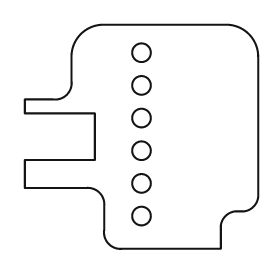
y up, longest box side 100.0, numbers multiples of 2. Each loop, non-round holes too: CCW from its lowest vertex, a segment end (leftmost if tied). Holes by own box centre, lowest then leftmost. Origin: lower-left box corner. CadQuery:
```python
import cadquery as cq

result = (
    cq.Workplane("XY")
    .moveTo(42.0, 0.0)
    .lineTo(84.0, 0.0)
    .lineTo(84.0, 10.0)
    .threePointArc((86.0, 14.0), (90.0, 16.0))
    .lineTo(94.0, 16.0)
    .threePointArc((98.0, 18.0), (100.0, 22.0))
    .lineTo(100.0, 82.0)
    .threePointArc((96.0, 92.0), (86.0, 96.0))
    .lineTo(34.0, 96.0)
    .threePointArc((24.0, 92.0), (20.0, 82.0))
    .lineTo(20.0, 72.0)
    .threePointArc((18.0, 66.0), (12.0, 64.0))
    .lineTo(0.0, 64.0)
    .lineTo(0.0, 58.0)
    .lineTo(30.0, 58.0)
    .lineTo(30.0, 38.0)
    .lineTo(0.0, 38.0)
    .lineTo(0.0, 26.0)
    .lineTo(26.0, 26.0)
    .threePointArc((32.0, 24.0), (34.0, 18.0))
    .lineTo(34.0, 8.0)
    .threePointArc((36.0, 2.0), (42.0, 0.0))
    .close()
    .moveTo(50.0, 14.0)
    .circle(4.0)
    .moveTo(50.0, 28.0)
    .circle(4.0)
    .moveTo(50.0, 42.0)
    .circle(4.0)
    .moveTo(50.0, 56.0)
    .circle(4.0)
    .moveTo(50.0, 70.0)
    .circle(4.0)
    .moveTo(50.0, 84.0)
    .circle(4.0)
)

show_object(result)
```